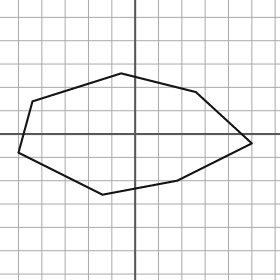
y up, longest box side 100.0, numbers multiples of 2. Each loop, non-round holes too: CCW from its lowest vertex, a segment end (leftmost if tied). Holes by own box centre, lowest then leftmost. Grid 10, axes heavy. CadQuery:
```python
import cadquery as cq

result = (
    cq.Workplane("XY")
    .moveTo(-14.0, -26.0)
    .lineTo(18.0, -20.0)
    .lineTo(50.0, -4.0)
    .lineTo(26.0, 18.0)
    .lineTo(-6.0, 26.0)
    .lineTo(-44.0, 14.0)
    .lineTo(-50.0, -8.0)
    .close()
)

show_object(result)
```